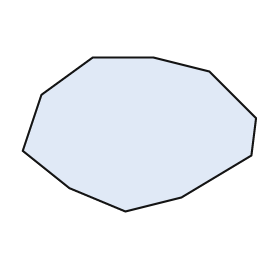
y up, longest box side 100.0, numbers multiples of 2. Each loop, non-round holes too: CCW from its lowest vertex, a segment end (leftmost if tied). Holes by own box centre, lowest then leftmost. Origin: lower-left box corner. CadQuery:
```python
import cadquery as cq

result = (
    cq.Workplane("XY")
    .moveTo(44.0, 0.0)
    .lineTo(68.0, 6.0)
    .lineTo(98.0, 24.0)
    .lineTo(100.0, 40.0)
    .lineTo(80.0, 60.0)
    .lineTo(56.0, 66.0)
    .lineTo(30.0, 66.0)
    .lineTo(8.0, 50.0)
    .lineTo(0.0, 26.0)
    .lineTo(20.0, 10.0)
    .close()
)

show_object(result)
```